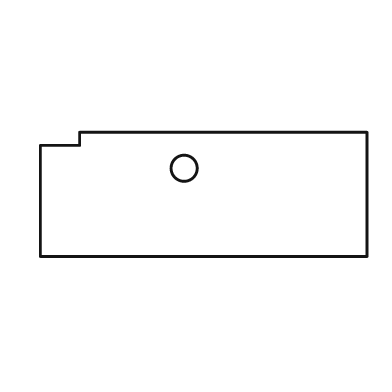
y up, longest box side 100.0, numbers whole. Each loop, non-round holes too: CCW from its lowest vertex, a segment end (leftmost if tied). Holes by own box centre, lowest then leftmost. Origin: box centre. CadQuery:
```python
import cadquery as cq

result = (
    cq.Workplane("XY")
    .moveTo(-50.0, -19.0)
    .lineTo(50.0, -19.0)
    .lineTo(50.0, 19.0)
    .lineTo(-38.0, 19.0)
    .lineTo(-38.0, 15.0)
    .lineTo(-50.0, 15.0)
    .close()
    .moveTo(-6.0, 8.0)
    .circle(4.0)
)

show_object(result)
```